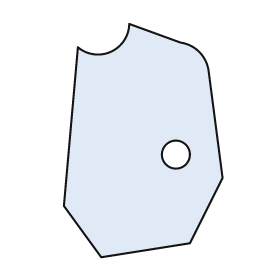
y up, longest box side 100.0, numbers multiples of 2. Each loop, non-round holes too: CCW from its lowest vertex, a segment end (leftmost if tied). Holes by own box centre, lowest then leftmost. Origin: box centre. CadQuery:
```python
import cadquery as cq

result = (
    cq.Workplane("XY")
    .moveTo(-18.0, -50.0)
    .lineTo(20.0, -44.0)
    .lineTo(34.0, -16.0)
    .lineTo(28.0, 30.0)
    .threePointArc((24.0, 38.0), (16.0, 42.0))
    .lineTo(-6.0, 50.0)
    .threePointArc((-14.0, 38.0), (-28.0, 40.0))
    .lineTo(-34.0, -28.0)
    .close()
    .moveTo(14.0, -6.0)
    .circle(6.0)
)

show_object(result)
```